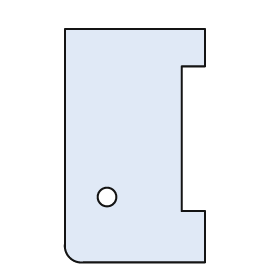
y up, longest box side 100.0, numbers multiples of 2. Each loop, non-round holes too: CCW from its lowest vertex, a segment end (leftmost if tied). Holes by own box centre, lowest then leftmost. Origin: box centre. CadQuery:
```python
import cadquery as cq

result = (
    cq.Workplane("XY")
    .moveTo(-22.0, -50.0)
    .lineTo(30.0, -50.0)
    .lineTo(30.0, -28.0)
    .lineTo(20.0, -28.0)
    .lineTo(20.0, 34.0)
    .lineTo(30.0, 34.0)
    .lineTo(30.0, 50.0)
    .lineTo(-30.0, 50.0)
    .lineTo(-30.0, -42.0)
    .threePointArc((-28.0, -48.0), (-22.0, -50.0))
    .close()
    .moveTo(-12.0, -22.0)
    .circle(4.0)
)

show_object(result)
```